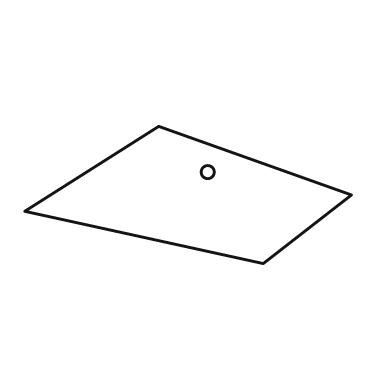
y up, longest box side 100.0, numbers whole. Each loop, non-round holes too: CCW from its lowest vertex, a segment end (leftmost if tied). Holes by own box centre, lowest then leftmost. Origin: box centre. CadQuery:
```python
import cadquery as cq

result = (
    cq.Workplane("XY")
    .moveTo(23.0, -21.0)
    .lineTo(50.0, 0.0)
    .lineTo(-9.0, 21.0)
    .lineTo(-50.0, -5.0)
    .close()
    .moveTo(6.0, 7.0)
    .circle(2.0)
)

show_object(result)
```